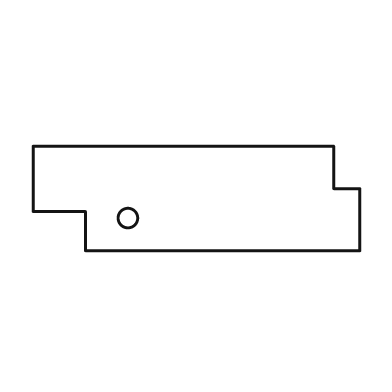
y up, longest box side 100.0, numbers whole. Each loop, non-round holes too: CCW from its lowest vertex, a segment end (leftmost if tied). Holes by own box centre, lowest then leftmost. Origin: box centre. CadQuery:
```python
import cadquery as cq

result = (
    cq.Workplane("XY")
    .moveTo(-34.0, -16.0)
    .lineTo(50.0, -16.0)
    .lineTo(50.0, 3.0)
    .lineTo(42.0, 3.0)
    .lineTo(42.0, 16.0)
    .lineTo(-50.0, 16.0)
    .lineTo(-50.0, -4.0)
    .lineTo(-34.0, -4.0)
    .close()
    .moveTo(-21.0, -6.0)
    .circle(3.0)
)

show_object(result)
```